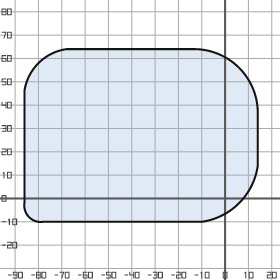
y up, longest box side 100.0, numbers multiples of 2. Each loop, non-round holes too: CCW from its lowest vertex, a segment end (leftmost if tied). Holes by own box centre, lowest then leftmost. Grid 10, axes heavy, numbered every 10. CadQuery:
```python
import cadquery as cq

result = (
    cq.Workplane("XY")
    .moveTo(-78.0, -10.0)
    .lineTo(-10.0, -10.0)
    .threePointArc((6.0, -2.0), (14.0, 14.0))
    .lineTo(14.0, 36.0)
    .threePointArc((6.0, 56.0), (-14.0, 64.0))
    .lineTo(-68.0, 64.0)
    .threePointArc((-80.0, 58.0), (-86.0, 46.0))
    .lineTo(-86.0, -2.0)
    .threePointArc((-84.0, -8.0), (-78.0, -10.0))
    .close()
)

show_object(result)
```